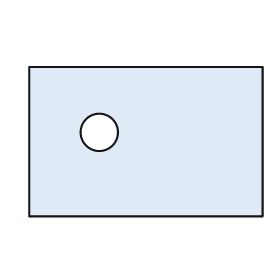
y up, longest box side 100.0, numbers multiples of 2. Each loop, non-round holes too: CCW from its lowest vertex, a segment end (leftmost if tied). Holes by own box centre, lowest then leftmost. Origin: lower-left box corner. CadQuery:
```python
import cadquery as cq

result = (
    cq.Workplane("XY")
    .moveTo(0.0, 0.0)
    .lineTo(100.0, 0.0)
    .lineTo(100.0, 64.0)
    .lineTo(0.0, 64.0)
    .close()
    .moveTo(30.0, 36.0)
    .circle(8.0)
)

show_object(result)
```